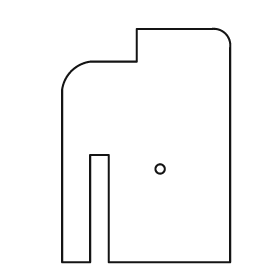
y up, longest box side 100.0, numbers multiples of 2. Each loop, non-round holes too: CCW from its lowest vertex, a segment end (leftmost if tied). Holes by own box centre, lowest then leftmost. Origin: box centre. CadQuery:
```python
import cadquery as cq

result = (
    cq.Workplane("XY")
    .moveTo(-36.0, -50.0)
    .lineTo(-24.0, -50.0)
    .lineTo(-24.0, -4.0)
    .lineTo(-16.0, -4.0)
    .lineTo(-16.0, -50.0)
    .lineTo(36.0, -50.0)
    .lineTo(36.0, 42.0)
    .threePointArc((34.0, 48.0), (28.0, 50.0))
    .lineTo(-4.0, 50.0)
    .lineTo(-4.0, 36.0)
    .lineTo(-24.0, 36.0)
    .threePointArc((-32.0, 32.0), (-36.0, 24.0))
    .close()
    .moveTo(6.0, -10.0)
    .circle(2.0)
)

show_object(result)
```